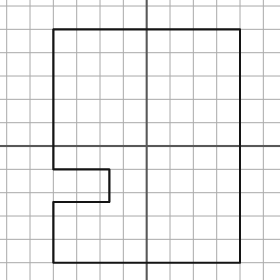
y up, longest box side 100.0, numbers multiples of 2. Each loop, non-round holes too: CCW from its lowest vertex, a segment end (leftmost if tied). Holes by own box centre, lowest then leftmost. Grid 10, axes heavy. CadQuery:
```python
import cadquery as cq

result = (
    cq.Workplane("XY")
    .moveTo(-40.0, -50.0)
    .lineTo(40.0, -50.0)
    .lineTo(40.0, 50.0)
    .lineTo(-40.0, 50.0)
    .lineTo(-40.0, -10.0)
    .lineTo(-16.0, -10.0)
    .lineTo(-16.0, -24.0)
    .lineTo(-40.0, -24.0)
    .close()
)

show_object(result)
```